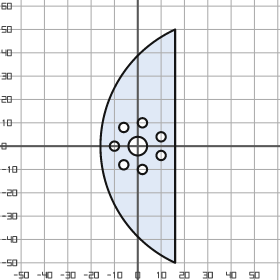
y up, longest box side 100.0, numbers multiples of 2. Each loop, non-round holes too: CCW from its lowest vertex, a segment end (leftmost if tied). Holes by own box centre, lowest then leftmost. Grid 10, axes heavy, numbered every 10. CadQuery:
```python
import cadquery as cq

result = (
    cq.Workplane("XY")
    .moveTo(16.0, -50.0)
    .lineTo(16.0, 50.0)
    .threePointArc((-16.0, 0.0), (16.0, -50.0))
    .close()
    .moveTo(2.0, -10.0)
    .circle(2.0)
    .moveTo(-6.0, -8.0)
    .circle(2.0)
    .moveTo(10.0, -4.0)
    .circle(2.0)
    .moveTo(-10.0, 0.0)
    .circle(2.0)
    .moveTo(0.0, 0.0)
    .circle(4.0)
    .moveTo(10.0, 4.0)
    .circle(2.0)
    .moveTo(-6.0, 8.0)
    .circle(2.0)
    .moveTo(2.0, 10.0)
    .circle(2.0)
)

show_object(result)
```